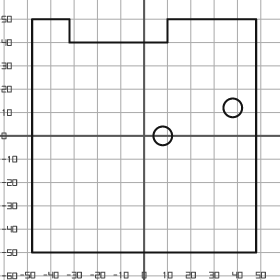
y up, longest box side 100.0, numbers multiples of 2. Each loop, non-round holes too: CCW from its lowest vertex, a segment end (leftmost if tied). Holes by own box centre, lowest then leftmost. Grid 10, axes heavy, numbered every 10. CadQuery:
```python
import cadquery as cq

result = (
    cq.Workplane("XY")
    .moveTo(-48.0, -50.0)
    .lineTo(48.0, -50.0)
    .lineTo(48.0, 50.0)
    .lineTo(10.0, 50.0)
    .lineTo(10.0, 40.0)
    .lineTo(-32.0, 40.0)
    .lineTo(-32.0, 50.0)
    .lineTo(-48.0, 50.0)
    .close()
    .moveTo(8.0, 0.0)
    .circle(4.0)
    .moveTo(38.0, 12.0)
    .circle(4.0)
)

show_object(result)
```